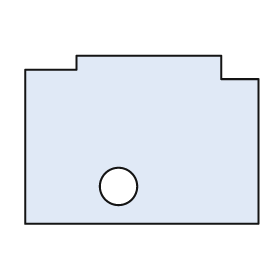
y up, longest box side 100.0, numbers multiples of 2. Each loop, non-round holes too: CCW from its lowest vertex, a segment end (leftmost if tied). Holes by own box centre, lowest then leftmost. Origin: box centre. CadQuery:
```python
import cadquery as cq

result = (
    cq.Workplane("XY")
    .moveTo(-50.0, -36.0)
    .lineTo(50.0, -36.0)
    .lineTo(50.0, 26.0)
    .lineTo(34.0, 26.0)
    .lineTo(34.0, 36.0)
    .lineTo(-28.0, 36.0)
    .lineTo(-28.0, 30.0)
    .lineTo(-50.0, 30.0)
    .close()
    .moveTo(-10.0, -20.0)
    .circle(8.0)
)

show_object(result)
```